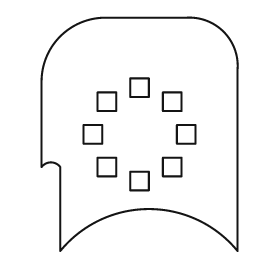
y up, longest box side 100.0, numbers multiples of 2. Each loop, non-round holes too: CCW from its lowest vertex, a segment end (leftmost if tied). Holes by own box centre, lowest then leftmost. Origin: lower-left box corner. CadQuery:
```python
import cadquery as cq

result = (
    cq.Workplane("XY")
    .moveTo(8.0, 0.0)
    .threePointArc((46.0, 18.0), (84.0, 0.0))
    .lineTo(84.0, 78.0)
    .threePointArc((78.0, 94.0), (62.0, 100.0))
    .lineTo(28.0, 100.0)
    .threePointArc((8.0, 92.0), (0.0, 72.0))
    .lineTo(0.0, 36.0)
    .threePointArc((4.0, 38.0), (8.0, 36.0))
    .close()
    .moveTo(38.0, 26.0)
    .lineTo(46.0, 26.0)
    .lineTo(46.0, 34.0)
    .lineTo(38.0, 34.0)
    .close()
    .moveTo(24.0, 32.0)
    .lineTo(32.0, 32.0)
    .lineTo(32.0, 40.0)
    .lineTo(24.0, 40.0)
    .close()
    .moveTo(52.0, 32.0)
    .lineTo(60.0, 32.0)
    .lineTo(60.0, 40.0)
    .lineTo(52.0, 40.0)
    .close()
    .moveTo(18.0, 46.0)
    .lineTo(26.0, 46.0)
    .lineTo(26.0, 54.0)
    .lineTo(18.0, 54.0)
    .close()
    .moveTo(58.0, 46.0)
    .lineTo(66.0, 46.0)
    .lineTo(66.0, 54.0)
    .lineTo(58.0, 54.0)
    .close()
    .moveTo(24.0, 60.0)
    .lineTo(32.0, 60.0)
    .lineTo(32.0, 68.0)
    .lineTo(24.0, 68.0)
    .close()
    .moveTo(52.0, 60.0)
    .lineTo(60.0, 60.0)
    .lineTo(60.0, 68.0)
    .lineTo(52.0, 68.0)
    .close()
    .moveTo(38.0, 66.0)
    .lineTo(46.0, 66.0)
    .lineTo(46.0, 74.0)
    .lineTo(38.0, 74.0)
    .close()
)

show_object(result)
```